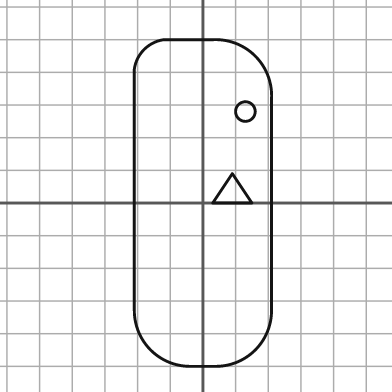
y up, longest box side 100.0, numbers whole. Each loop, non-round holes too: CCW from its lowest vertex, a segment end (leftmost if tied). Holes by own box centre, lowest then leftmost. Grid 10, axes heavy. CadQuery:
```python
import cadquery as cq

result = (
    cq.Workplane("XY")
    .moveTo(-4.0, -50.0)
    .lineTo(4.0, -50.0)
    .threePointArc((16.0, -45.0), (21.0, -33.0))
    .lineTo(21.0, 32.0)
    .threePointArc((16.0, 45.0), (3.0, 50.0))
    .lineTo(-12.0, 50.0)
    .threePointArc((-18.0, 47.0), (-21.0, 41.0))
    .lineTo(-21.0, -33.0)
    .threePointArc((-16.0, -45.0), (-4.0, -50.0))
    .close()
    .moveTo(3.0, 0.0)
    .lineTo(15.0, 0.0)
    .lineTo(9.0, 9.0)
    .close()
    .moveTo(13.0, 28.0)
    .circle(3.0)
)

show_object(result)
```